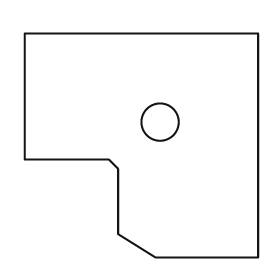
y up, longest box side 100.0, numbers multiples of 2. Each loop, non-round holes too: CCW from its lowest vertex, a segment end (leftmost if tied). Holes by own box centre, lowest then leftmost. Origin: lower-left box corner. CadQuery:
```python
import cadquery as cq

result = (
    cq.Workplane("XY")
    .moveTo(56.0, 0.0)
    .lineTo(100.0, 0.0)
    .lineTo(100.0, 96.0)
    .lineTo(0.0, 96.0)
    .lineTo(0.0, 42.0)
    .lineTo(36.0, 42.0)
    .lineTo(40.0, 38.0)
    .lineTo(40.0, 10.0)
    .close()
    .moveTo(58.0, 58.0)
    .circle(8.0)
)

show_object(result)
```